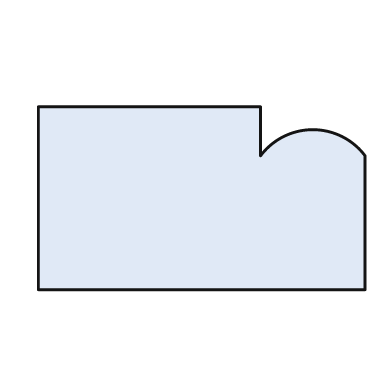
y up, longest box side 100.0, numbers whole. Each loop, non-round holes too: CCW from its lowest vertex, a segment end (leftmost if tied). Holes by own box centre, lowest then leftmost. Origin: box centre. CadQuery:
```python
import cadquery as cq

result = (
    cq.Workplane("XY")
    .moveTo(-50.0, -28.0)
    .lineTo(50.0, -28.0)
    .lineTo(50.0, 13.0)
    .threePointArc((34.0, 21.0), (18.0, 13.0))
    .lineTo(18.0, 28.0)
    .lineTo(-50.0, 28.0)
    .close()
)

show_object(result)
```